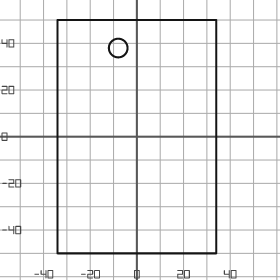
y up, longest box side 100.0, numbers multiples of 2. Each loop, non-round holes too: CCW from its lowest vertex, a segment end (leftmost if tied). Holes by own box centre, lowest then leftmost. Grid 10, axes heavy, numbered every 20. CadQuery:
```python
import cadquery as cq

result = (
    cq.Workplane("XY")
    .moveTo(-34.0, -50.0)
    .lineTo(34.0, -50.0)
    .lineTo(34.0, 50.0)
    .lineTo(-34.0, 50.0)
    .close()
    .moveTo(-8.0, 38.0)
    .circle(4.0)
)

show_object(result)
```